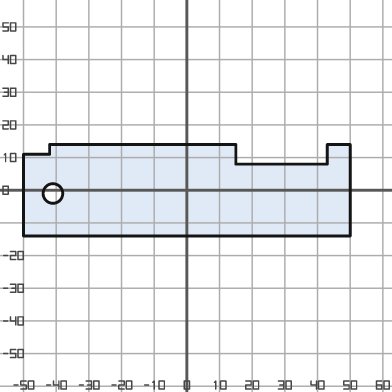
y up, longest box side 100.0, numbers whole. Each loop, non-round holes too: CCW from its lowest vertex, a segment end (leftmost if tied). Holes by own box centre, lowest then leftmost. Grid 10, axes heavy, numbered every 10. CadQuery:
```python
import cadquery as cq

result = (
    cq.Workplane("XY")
    .moveTo(-50.0, -14.0)
    .lineTo(50.0, -14.0)
    .lineTo(50.0, 14.0)
    .lineTo(43.0, 14.0)
    .lineTo(43.0, 8.0)
    .lineTo(15.0, 8.0)
    .lineTo(15.0, 14.0)
    .lineTo(-42.0, 14.0)
    .lineTo(-42.0, 11.0)
    .lineTo(-50.0, 11.0)
    .close()
    .moveTo(-41.0, -1.0)
    .circle(3.0)
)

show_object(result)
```